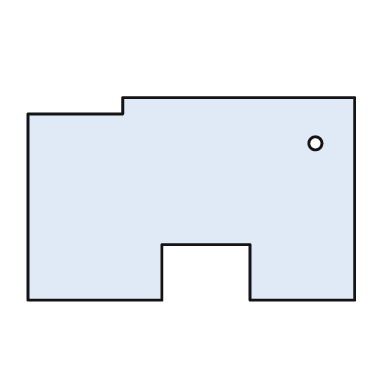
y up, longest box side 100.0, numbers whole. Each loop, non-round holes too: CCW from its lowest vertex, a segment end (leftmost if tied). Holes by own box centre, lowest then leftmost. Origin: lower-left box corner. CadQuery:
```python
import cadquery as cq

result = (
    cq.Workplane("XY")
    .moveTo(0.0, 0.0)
    .lineTo(41.0, 0.0)
    .lineTo(41.0, 17.0)
    .lineTo(68.0, 17.0)
    .lineTo(68.0, 0.0)
    .lineTo(100.0, 0.0)
    .lineTo(100.0, 62.0)
    .lineTo(29.0, 62.0)
    .lineTo(29.0, 57.0)
    .lineTo(0.0, 57.0)
    .close()
    .moveTo(88.0, 48.0)
    .circle(2.0)
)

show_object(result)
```